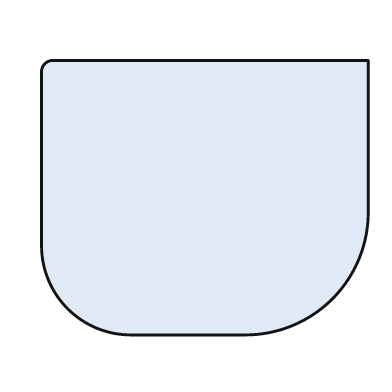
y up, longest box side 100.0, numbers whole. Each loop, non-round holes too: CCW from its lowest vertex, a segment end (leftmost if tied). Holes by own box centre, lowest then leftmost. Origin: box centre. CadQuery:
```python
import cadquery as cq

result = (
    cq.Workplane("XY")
    .moveTo(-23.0, -42.0)
    .lineTo(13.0, -42.0)
    .threePointArc((39.0, -31.0), (50.0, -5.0))
    .lineTo(50.0, 42.0)
    .lineTo(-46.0, 42.0)
    .threePointArc((-49.0, 41.0), (-50.0, 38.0))
    .lineTo(-50.0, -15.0)
    .threePointArc((-42.0, -34.0), (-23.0, -42.0))
    .close()
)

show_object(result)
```